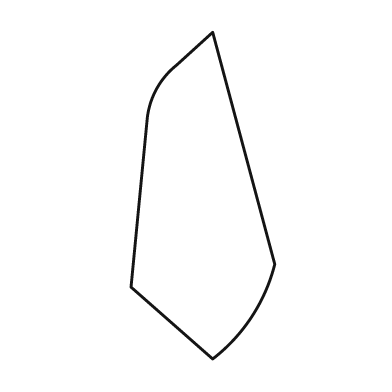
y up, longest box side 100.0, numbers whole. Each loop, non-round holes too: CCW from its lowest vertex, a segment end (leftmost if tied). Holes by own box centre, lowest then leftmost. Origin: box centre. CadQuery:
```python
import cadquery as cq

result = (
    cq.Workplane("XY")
    .moveTo(3.0, -50.0)
    .threePointArc((15.0, -37.0), (22.0, -21.0))
    .lineTo(3.0, 50.0)
    .lineTo(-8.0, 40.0)
    .threePointArc((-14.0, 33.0), (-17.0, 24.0))
    .lineTo(-22.0, -28.0)
    .close()
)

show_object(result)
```